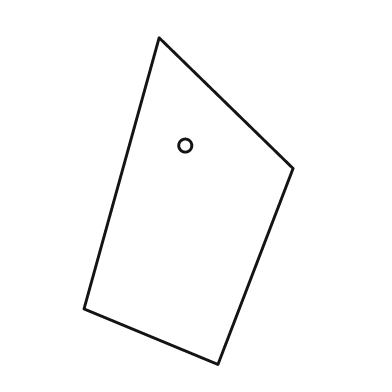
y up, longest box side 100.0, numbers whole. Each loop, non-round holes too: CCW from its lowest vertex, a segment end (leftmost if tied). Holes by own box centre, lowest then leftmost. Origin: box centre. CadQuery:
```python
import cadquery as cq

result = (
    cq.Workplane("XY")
    .moveTo(9.0, -50.0)
    .lineTo(32.0, 10.0)
    .lineTo(-9.0, 50.0)
    .lineTo(-32.0, -33.0)
    .close()
    .moveTo(-1.0, 17.0)
    .circle(2.0)
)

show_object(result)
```